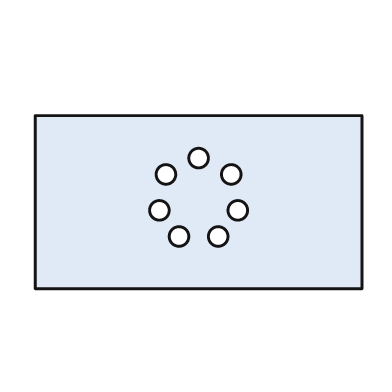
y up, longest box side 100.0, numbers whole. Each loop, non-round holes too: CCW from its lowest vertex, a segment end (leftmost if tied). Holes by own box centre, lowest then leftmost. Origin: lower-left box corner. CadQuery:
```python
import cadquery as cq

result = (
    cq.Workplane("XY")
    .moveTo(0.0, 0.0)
    .lineTo(100.0, 0.0)
    .lineTo(100.0, 53.0)
    .lineTo(0.0, 53.0)
    .close()
    .moveTo(44.0, 16.0)
    .circle(3.0)
    .moveTo(56.0, 16.0)
    .circle(3.0)
    .moveTo(38.0, 24.0)
    .circle(3.0)
    .moveTo(62.0, 24.0)
    .circle(3.0)
    .moveTo(40.0, 35.0)
    .circle(3.0)
    .moveTo(60.0, 35.0)
    .circle(3.0)
    .moveTo(50.0, 40.0)
    .circle(3.0)
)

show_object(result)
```